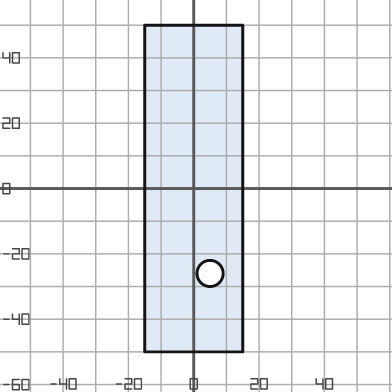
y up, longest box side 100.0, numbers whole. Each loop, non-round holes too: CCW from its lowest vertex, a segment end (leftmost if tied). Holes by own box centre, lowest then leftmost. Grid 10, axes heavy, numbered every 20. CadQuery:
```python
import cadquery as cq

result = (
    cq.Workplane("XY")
    .moveTo(-15.0, -50.0)
    .lineTo(15.0, -50.0)
    .lineTo(15.0, 50.0)
    .lineTo(-15.0, 50.0)
    .close()
    .moveTo(5.0, -26.0)
    .circle(4.0)
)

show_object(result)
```